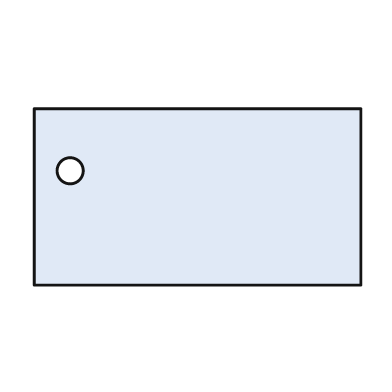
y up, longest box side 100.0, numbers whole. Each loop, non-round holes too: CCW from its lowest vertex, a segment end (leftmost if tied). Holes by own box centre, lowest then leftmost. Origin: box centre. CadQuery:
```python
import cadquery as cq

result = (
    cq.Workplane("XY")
    .moveTo(-50.0, -27.0)
    .lineTo(50.0, -27.0)
    .lineTo(50.0, 27.0)
    .lineTo(-50.0, 27.0)
    .close()
    .moveTo(-39.0, 8.0)
    .circle(4.0)
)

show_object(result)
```